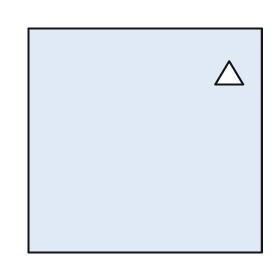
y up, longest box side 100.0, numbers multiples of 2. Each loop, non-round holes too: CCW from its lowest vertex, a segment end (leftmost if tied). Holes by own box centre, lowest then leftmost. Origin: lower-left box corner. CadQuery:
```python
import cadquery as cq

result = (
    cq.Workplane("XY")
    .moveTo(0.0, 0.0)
    .lineTo(100.0, 0.0)
    .lineTo(100.0, 96.0)
    .lineTo(0.0, 96.0)
    .close()
    .moveTo(80.0, 72.0)
    .lineTo(92.0, 72.0)
    .lineTo(86.0, 82.0)
    .close()
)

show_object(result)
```